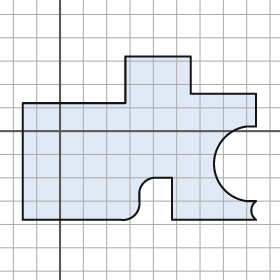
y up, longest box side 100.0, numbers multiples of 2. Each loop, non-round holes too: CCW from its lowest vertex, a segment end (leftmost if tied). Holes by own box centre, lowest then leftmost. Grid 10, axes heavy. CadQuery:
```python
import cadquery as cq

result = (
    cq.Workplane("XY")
    .moveTo(-16.0, -38.0)
    .lineTo(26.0, -38.0)
    .threePointArc((32.0, -36.0), (34.0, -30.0))
    .lineTo(34.0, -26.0)
    .threePointArc((36.0, -22.0), (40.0, -20.0))
    .lineTo(48.0, -20.0)
    .lineTo(48.0, -38.0)
    .lineTo(84.0, -38.0)
    .threePointArc((82.0, -34.0), (84.0, -30.0))
    .lineTo(80.0, -30.0)
    .threePointArc((66.0, -14.0), (80.0, 2.0))
    .lineTo(84.0, 2.0)
    .lineTo(84.0, 16.0)
    .lineTo(56.0, 16.0)
    .lineTo(56.0, 32.0)
    .lineTo(28.0, 32.0)
    .lineTo(28.0, 12.0)
    .lineTo(-16.0, 12.0)
    .close()
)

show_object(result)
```